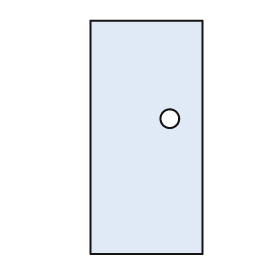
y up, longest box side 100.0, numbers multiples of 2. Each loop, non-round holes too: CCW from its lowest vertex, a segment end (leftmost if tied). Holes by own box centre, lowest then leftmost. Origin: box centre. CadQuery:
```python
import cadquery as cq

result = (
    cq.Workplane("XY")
    .moveTo(-24.0, -50.0)
    .lineTo(24.0, -50.0)
    .lineTo(24.0, 50.0)
    .lineTo(-24.0, 50.0)
    .close()
    .moveTo(10.0, 8.0)
    .circle(4.0)
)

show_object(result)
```